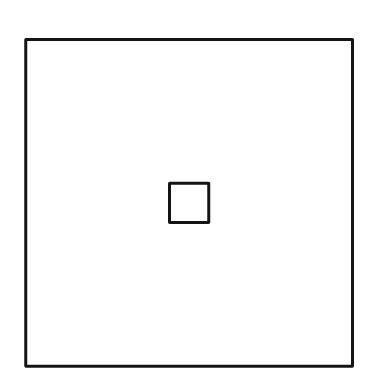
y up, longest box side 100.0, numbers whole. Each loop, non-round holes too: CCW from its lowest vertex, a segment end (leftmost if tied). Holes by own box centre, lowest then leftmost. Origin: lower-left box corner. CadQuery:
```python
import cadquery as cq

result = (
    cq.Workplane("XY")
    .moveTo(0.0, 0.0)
    .lineTo(100.0, 0.0)
    .lineTo(100.0, 100.0)
    .lineTo(0.0, 100.0)
    .close()
    .moveTo(44.0, 44.0)
    .lineTo(56.0, 44.0)
    .lineTo(56.0, 56.0)
    .lineTo(44.0, 56.0)
    .close()
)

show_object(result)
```